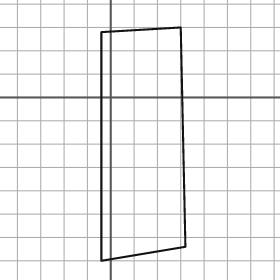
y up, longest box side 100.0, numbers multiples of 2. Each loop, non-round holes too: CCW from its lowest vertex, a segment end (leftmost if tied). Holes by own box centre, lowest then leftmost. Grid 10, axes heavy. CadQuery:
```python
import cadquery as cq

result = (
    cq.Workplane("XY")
    .moveTo(-4.0, -70.0)
    .lineTo(32.0, -64.0)
    .lineTo(30.0, 30.0)
    .lineTo(-4.0, 28.0)
    .close()
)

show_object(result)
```